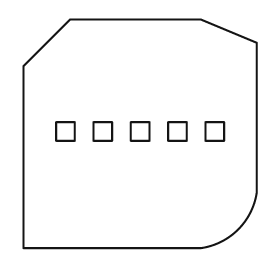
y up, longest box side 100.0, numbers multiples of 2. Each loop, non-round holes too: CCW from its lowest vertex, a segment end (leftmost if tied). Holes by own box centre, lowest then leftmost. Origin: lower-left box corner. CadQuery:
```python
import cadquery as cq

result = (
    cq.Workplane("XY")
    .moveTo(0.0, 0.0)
    .lineTo(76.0, 0.0)
    .threePointArc((92.0, 8.0), (100.0, 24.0))
    .lineTo(100.0, 88.0)
    .lineTo(76.0, 98.0)
    .lineTo(20.0, 98.0)
    .lineTo(0.0, 78.0)
    .close()
    .moveTo(14.0, 46.0)
    .lineTo(22.0, 46.0)
    .lineTo(22.0, 54.0)
    .lineTo(14.0, 54.0)
    .close()
    .moveTo(30.0, 46.0)
    .lineTo(38.0, 46.0)
    .lineTo(38.0, 54.0)
    .lineTo(30.0, 54.0)
    .close()
    .moveTo(46.0, 46.0)
    .lineTo(54.0, 46.0)
    .lineTo(54.0, 54.0)
    .lineTo(46.0, 54.0)
    .close()
    .moveTo(62.0, 46.0)
    .lineTo(70.0, 46.0)
    .lineTo(70.0, 54.0)
    .lineTo(62.0, 54.0)
    .close()
    .moveTo(78.0, 46.0)
    .lineTo(86.0, 46.0)
    .lineTo(86.0, 54.0)
    .lineTo(78.0, 54.0)
    .close()
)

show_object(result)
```